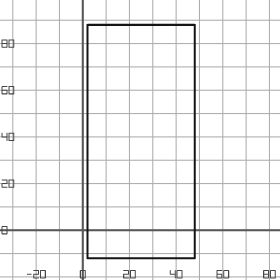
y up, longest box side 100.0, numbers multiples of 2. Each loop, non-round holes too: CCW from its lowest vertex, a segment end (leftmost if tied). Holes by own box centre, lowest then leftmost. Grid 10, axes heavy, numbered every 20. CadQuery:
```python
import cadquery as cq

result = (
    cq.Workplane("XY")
    .moveTo(2.0, -12.0)
    .lineTo(48.0, -12.0)
    .lineTo(48.0, 88.0)
    .lineTo(2.0, 88.0)
    .close()
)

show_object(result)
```